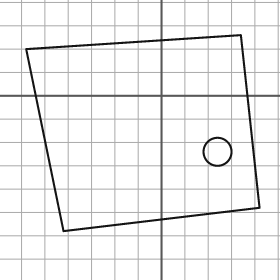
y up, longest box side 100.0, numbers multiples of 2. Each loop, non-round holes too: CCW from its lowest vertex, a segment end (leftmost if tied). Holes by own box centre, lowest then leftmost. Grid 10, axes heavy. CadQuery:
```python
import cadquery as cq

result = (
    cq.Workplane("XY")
    .moveTo(-42.0, -58.0)
    .lineTo(42.0, -48.0)
    .lineTo(34.0, 26.0)
    .lineTo(-58.0, 20.0)
    .close()
    .moveTo(24.0, -24.0)
    .circle(6.0)
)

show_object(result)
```